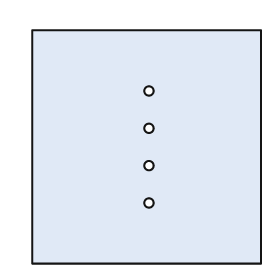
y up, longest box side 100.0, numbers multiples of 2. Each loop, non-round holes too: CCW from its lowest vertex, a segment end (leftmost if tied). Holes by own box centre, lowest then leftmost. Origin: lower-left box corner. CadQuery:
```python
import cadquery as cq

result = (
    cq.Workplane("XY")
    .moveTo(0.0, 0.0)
    .lineTo(98.0, 0.0)
    .lineTo(98.0, 100.0)
    .lineTo(0.0, 100.0)
    .close()
    .moveTo(50.0, 26.0)
    .circle(2.0)
    .moveTo(50.0, 42.0)
    .circle(2.0)
    .moveTo(50.0, 58.0)
    .circle(2.0)
    .moveTo(50.0, 74.0)
    .circle(2.0)
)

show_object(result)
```